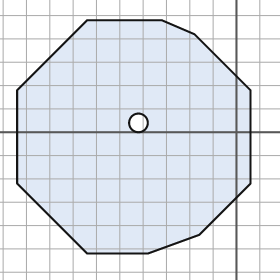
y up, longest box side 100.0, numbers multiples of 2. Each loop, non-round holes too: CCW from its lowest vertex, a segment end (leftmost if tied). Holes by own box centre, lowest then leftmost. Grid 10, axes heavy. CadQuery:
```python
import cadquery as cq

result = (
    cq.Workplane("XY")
    .moveTo(-64.0, -52.0)
    .lineTo(-38.0, -52.0)
    .lineTo(-16.0, -44.0)
    .lineTo(6.0, -22.0)
    .lineTo(6.0, 18.0)
    .lineTo(-18.0, 42.0)
    .lineTo(-32.0, 48.0)
    .lineTo(-64.0, 48.0)
    .lineTo(-94.0, 18.0)
    .lineTo(-94.0, -22.0)
    .close()
    .moveTo(-42.0, 4.0)
    .circle(4.0)
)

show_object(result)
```